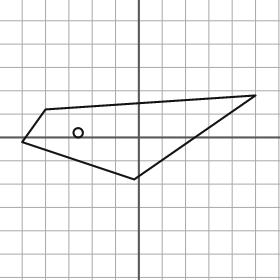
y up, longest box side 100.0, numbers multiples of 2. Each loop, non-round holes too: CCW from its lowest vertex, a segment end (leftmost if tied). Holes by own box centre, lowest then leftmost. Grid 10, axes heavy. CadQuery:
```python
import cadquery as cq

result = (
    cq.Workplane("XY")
    .moveTo(-2.0, -18.0)
    .lineTo(50.0, 18.0)
    .lineTo(-40.0, 12.0)
    .lineTo(-50.0, -2.0)
    .close()
    .moveTo(-26.0, 2.0)
    .circle(2.0)
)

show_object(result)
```